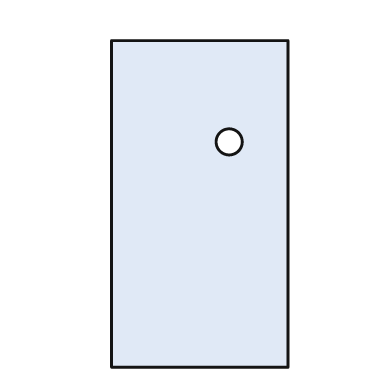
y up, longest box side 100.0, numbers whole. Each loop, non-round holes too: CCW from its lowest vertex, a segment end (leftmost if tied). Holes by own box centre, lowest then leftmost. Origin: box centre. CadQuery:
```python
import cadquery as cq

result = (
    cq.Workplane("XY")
    .moveTo(-27.0, -50.0)
    .lineTo(27.0, -50.0)
    .lineTo(27.0, 50.0)
    .lineTo(-27.0, 50.0)
    .close()
    .moveTo(9.0, 19.0)
    .circle(4.0)
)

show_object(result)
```